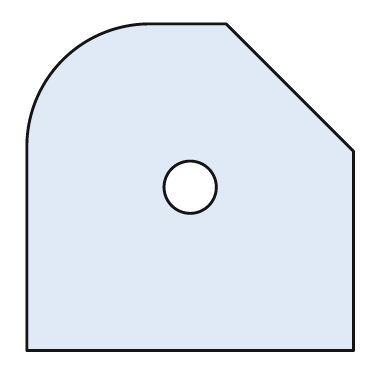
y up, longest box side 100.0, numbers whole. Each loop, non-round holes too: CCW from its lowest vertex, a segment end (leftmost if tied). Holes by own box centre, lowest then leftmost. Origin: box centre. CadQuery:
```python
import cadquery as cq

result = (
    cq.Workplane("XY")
    .moveTo(-50.0, -50.0)
    .lineTo(50.0, -50.0)
    .lineTo(50.0, 11.0)
    .lineTo(11.0, 50.0)
    .lineTo(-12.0, 50.0)
    .threePointArc((-39.0, 39.0), (-50.0, 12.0))
    .close()
    .moveTo(0.0, 0.0)
    .circle(8.0)
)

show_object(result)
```